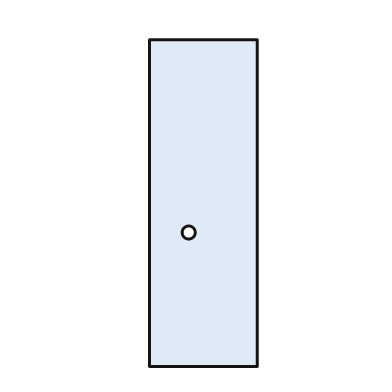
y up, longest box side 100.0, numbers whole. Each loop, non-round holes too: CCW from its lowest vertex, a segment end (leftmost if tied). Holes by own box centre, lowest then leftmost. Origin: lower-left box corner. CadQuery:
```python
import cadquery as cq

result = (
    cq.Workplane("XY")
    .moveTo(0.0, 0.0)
    .lineTo(33.0, 0.0)
    .lineTo(33.0, 100.0)
    .lineTo(0.0, 100.0)
    .close()
    .moveTo(12.0, 41.0)
    .circle(2.0)
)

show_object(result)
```